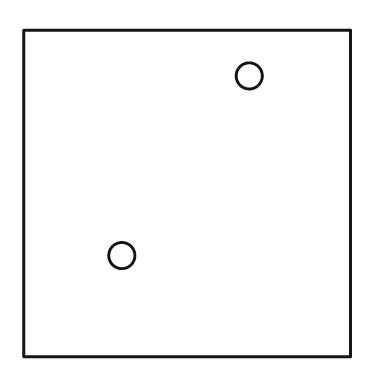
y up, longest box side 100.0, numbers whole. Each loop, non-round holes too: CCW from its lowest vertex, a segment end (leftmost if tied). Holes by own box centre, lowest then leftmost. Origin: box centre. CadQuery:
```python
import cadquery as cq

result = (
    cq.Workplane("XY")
    .moveTo(-50.0, -50.0)
    .lineTo(50.0, -50.0)
    .lineTo(50.0, 50.0)
    .lineTo(-50.0, 50.0)
    .close()
    .moveTo(-20.0, -19.0)
    .circle(4.0)
    .moveTo(19.0, 36.0)
    .circle(4.0)
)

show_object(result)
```